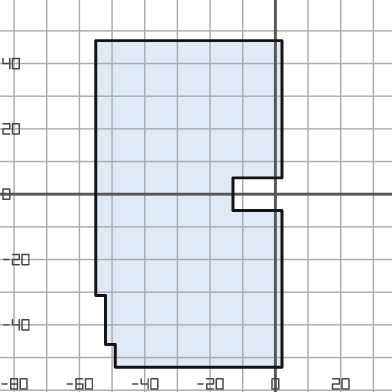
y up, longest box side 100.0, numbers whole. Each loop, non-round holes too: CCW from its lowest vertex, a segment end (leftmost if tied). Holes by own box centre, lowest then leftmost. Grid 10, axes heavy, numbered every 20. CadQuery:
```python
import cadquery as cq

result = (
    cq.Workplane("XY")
    .moveTo(-49.0, -53.0)
    .lineTo(2.0, -53.0)
    .lineTo(2.0, -5.0)
    .lineTo(-13.0, -5.0)
    .lineTo(-13.0, 5.0)
    .lineTo(2.0, 5.0)
    .lineTo(2.0, 47.0)
    .lineTo(-55.0, 47.0)
    .lineTo(-55.0, -31.0)
    .lineTo(-52.0, -31.0)
    .lineTo(-52.0, -46.0)
    .lineTo(-49.0, -46.0)
    .close()
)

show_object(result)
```